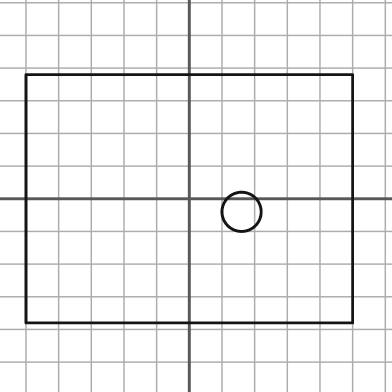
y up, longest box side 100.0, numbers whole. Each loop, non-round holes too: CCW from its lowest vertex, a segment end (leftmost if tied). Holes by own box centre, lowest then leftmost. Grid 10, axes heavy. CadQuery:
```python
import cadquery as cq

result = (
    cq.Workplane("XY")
    .moveTo(-50.0, -38.0)
    .lineTo(50.0, -38.0)
    .lineTo(50.0, 38.0)
    .lineTo(-50.0, 38.0)
    .close()
    .moveTo(16.0, -4.0)
    .circle(6.0)
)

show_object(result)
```